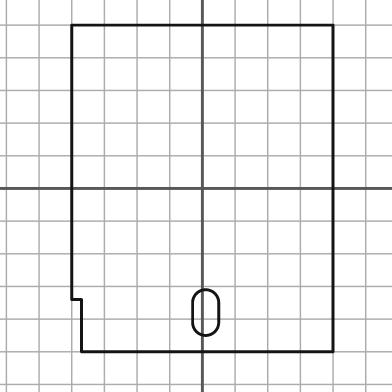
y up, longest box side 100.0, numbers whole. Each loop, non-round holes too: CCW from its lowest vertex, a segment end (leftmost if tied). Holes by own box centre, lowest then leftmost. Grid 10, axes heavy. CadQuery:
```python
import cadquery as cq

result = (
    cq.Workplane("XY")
    .moveTo(-37.0, -50.0)
    .lineTo(40.0, -50.0)
    .lineTo(40.0, 50.0)
    .lineTo(-40.0, 50.0)
    .lineTo(-40.0, -34.0)
    .lineTo(-37.0, -34.0)
    .close()
    .moveTo(-3.0, -41.0)
    .threePointArc((1.0, -45.0), (5.0, -41.0))
    .lineTo(5.0, -35.0)
    .threePointArc((1.0, -31.0), (-3.0, -35.0))
    .close()
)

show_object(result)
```